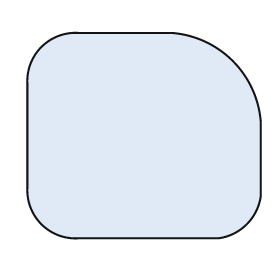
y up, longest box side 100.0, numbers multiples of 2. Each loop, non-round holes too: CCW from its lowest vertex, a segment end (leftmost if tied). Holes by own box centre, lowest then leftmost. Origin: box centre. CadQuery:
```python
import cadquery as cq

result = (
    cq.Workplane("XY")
    .moveTo(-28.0, -44.0)
    .lineTo(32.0, -44.0)
    .threePointArc((44.0, -38.0), (50.0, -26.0))
    .lineTo(50.0, 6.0)
    .threePointArc((38.0, 32.0), (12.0, 44.0))
    .lineTo(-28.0, 44.0)
    .threePointArc((-44.0, 38.0), (-50.0, 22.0))
    .lineTo(-50.0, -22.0)
    .threePointArc((-44.0, -38.0), (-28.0, -44.0))
    .close()
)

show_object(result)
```